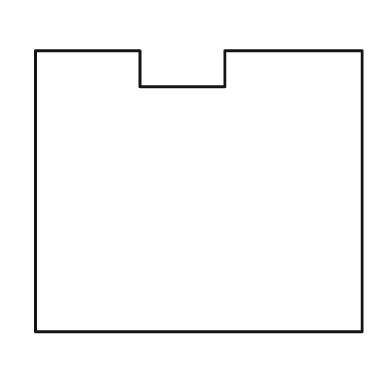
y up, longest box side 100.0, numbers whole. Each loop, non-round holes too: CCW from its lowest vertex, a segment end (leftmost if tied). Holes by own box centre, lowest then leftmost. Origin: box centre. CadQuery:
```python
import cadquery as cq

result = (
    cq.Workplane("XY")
    .moveTo(-50.0, -43.0)
    .lineTo(50.0, -43.0)
    .lineTo(50.0, 43.0)
    .lineTo(8.0, 43.0)
    .lineTo(8.0, 32.0)
    .lineTo(-18.0, 32.0)
    .lineTo(-18.0, 43.0)
    .lineTo(-50.0, 43.0)
    .close()
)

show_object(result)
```